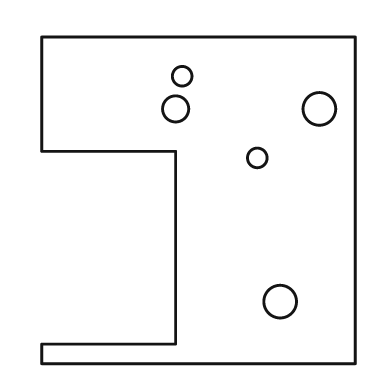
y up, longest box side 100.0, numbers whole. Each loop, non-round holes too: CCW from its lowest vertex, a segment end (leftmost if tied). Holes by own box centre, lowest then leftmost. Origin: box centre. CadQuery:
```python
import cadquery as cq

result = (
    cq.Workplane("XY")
    .moveTo(-48.0, -50.0)
    .lineTo(48.0, -50.0)
    .lineTo(48.0, 50.0)
    .lineTo(-48.0, 50.0)
    .lineTo(-48.0, 15.0)
    .lineTo(-7.0, 15.0)
    .lineTo(-7.0, -44.0)
    .lineTo(-48.0, -44.0)
    .close()
    .moveTo(25.0, -31.0)
    .circle(5.0)
    .moveTo(18.0, 13.0)
    .circle(3.0)
    .moveTo(-7.0, 28.0)
    .circle(4.0)
    .moveTo(37.0, 28.0)
    .circle(5.0)
    .moveTo(-5.0, 38.0)
    .circle(3.0)
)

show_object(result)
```